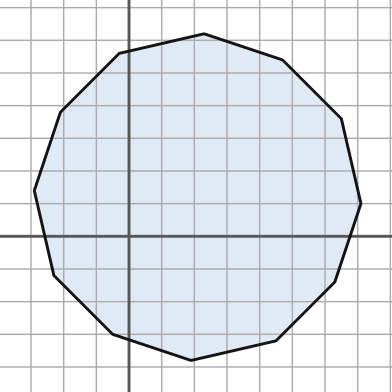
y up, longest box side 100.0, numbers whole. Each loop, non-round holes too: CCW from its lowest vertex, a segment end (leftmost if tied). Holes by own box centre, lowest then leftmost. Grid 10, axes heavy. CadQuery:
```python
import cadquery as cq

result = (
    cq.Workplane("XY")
    .moveTo(19.0, -38.0)
    .lineTo(45.0, -32.0)
    .lineTo(63.0, -14.0)
    .lineTo(71.0, 10.0)
    .lineTo(65.0, 36.0)
    .lineTo(47.0, 54.0)
    .lineTo(23.0, 62.0)
    .lineTo(-3.0, 56.0)
    .lineTo(-21.0, 38.0)
    .lineTo(-29.0, 14.0)
    .lineTo(-23.0, -12.0)
    .lineTo(-5.0, -30.0)
    .close()
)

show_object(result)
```